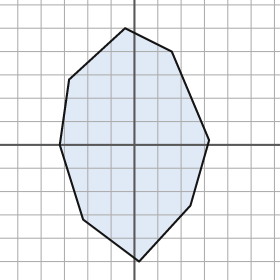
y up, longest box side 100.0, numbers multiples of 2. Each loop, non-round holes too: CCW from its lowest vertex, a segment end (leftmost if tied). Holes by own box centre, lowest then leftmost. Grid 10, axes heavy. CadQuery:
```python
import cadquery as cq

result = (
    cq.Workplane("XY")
    .moveTo(2.0, -50.0)
    .lineTo(24.0, -26.0)
    .lineTo(32.0, 2.0)
    .lineTo(16.0, 40.0)
    .lineTo(-4.0, 50.0)
    .lineTo(-28.0, 28.0)
    .lineTo(-32.0, 0.0)
    .lineTo(-22.0, -32.0)
    .close()
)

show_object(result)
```